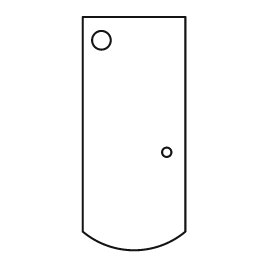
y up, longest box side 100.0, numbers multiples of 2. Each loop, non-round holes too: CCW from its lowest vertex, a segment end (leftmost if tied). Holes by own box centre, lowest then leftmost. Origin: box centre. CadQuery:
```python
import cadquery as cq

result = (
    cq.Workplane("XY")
    .moveTo(-22.0, -42.0)
    .threePointArc((0.0, -50.0), (22.0, -42.0))
    .lineTo(22.0, 50.0)
    .lineTo(-22.0, 50.0)
    .close()
    .moveTo(14.0, -8.0)
    .circle(2.0)
    .moveTo(-14.0, 40.0)
    .circle(4.0)
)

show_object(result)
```